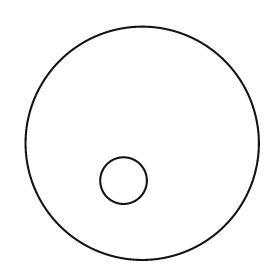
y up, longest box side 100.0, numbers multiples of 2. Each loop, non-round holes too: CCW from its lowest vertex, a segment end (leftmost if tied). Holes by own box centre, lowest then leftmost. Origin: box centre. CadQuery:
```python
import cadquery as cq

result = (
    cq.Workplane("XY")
    .moveTo(0.0, 0.0)
    .circle(50.0)
    .moveTo(-8.0, -16.0)
    .circle(10.0)
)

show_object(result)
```